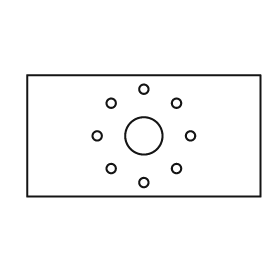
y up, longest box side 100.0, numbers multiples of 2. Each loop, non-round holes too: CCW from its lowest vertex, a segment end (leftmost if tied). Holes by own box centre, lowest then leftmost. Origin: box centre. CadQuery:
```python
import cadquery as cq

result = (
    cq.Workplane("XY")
    .moveTo(-50.0, -26.0)
    .lineTo(50.0, -26.0)
    .lineTo(50.0, 26.0)
    .lineTo(-50.0, 26.0)
    .close()
    .moveTo(0.0, -20.0)
    .circle(2.0)
    .moveTo(-14.0, -14.0)
    .circle(2.0)
    .moveTo(14.0, -14.0)
    .circle(2.0)
    .moveTo(-20.0, 0.0)
    .circle(2.0)
    .moveTo(0.0, 0.0)
    .circle(8.0)
    .moveTo(20.0, 0.0)
    .circle(2.0)
    .moveTo(-14.0, 14.0)
    .circle(2.0)
    .moveTo(14.0, 14.0)
    .circle(2.0)
    .moveTo(0.0, 20.0)
    .circle(2.0)
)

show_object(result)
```